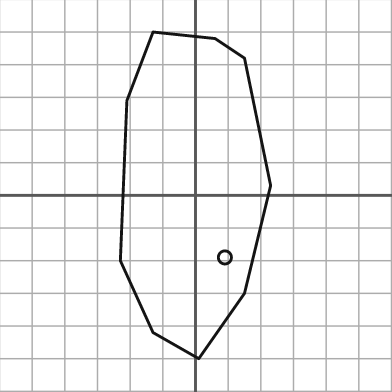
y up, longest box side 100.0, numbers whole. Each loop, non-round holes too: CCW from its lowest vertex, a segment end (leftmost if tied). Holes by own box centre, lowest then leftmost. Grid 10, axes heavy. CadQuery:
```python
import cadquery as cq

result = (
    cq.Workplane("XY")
    .moveTo(1.0, -50.0)
    .lineTo(15.0, -30.0)
    .lineTo(23.0, 3.0)
    .lineTo(15.0, 42.0)
    .lineTo(6.0, 48.0)
    .lineTo(-13.0, 50.0)
    .lineTo(-21.0, 29.0)
    .lineTo(-23.0, -20.0)
    .lineTo(-13.0, -42.0)
    .close()
    .moveTo(9.0, -19.0)
    .circle(2.0)
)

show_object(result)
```